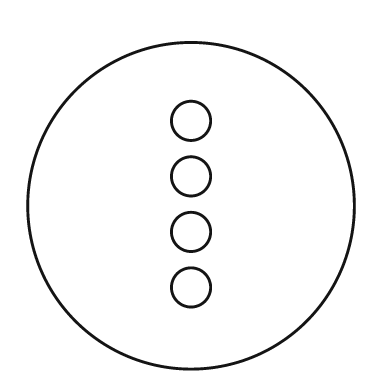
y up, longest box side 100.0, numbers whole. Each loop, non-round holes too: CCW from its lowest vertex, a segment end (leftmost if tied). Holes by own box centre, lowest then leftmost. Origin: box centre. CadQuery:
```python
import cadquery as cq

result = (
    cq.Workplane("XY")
    .moveTo(0.0, 0.0)
    .circle(50.0)
    .moveTo(0.0, -25.0)
    .circle(6.0)
    .moveTo(0.0, -8.0)
    .circle(6.0)
    .moveTo(0.0, 9.0)
    .circle(6.0)
    .moveTo(0.0, 26.0)
    .circle(6.0)
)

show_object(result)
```